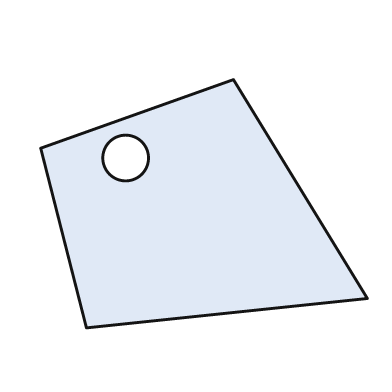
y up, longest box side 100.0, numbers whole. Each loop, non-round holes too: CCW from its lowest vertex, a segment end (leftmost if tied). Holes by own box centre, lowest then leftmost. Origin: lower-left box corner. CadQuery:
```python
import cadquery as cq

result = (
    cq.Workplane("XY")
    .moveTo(14.0, 0.0)
    .lineTo(100.0, 9.0)
    .lineTo(59.0, 76.0)
    .lineTo(0.0, 55.0)
    .close()
    .moveTo(26.0, 52.0)
    .circle(7.0)
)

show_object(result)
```